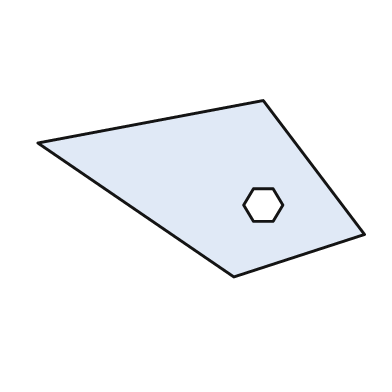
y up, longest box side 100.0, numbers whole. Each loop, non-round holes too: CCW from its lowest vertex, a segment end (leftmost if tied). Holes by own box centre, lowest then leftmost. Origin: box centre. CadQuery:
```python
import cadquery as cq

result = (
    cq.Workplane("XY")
    .moveTo(10.0, -27.0)
    .lineTo(50.0, -14.0)
    .lineTo(19.0, 27.0)
    .lineTo(-50.0, 14.0)
    .close()
    .moveTo(16.0, -10.0)
    .lineTo(22.0, -10.0)
    .lineTo(25.0, -5.0)
    .lineTo(22.0, 0.0)
    .lineTo(16.0, 0.0)
    .lineTo(13.0, -5.0)
    .close()
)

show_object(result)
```